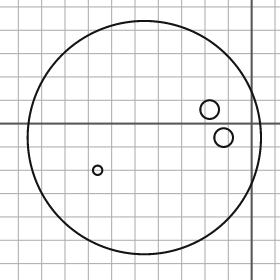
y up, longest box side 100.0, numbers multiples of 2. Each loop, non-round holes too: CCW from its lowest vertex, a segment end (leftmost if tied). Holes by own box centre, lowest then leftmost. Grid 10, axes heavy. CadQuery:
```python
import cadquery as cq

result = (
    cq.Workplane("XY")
    .moveTo(-46.0, -6.0)
    .circle(50.0)
    .moveTo(-66.0, -20.0)
    .circle(2.0)
    .moveTo(-12.0, -6.0)
    .circle(4.0)
    .moveTo(-18.0, 6.0)
    .circle(4.0)
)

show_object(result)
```